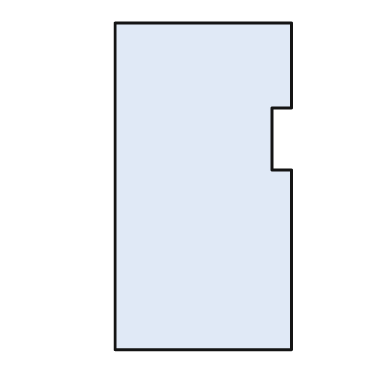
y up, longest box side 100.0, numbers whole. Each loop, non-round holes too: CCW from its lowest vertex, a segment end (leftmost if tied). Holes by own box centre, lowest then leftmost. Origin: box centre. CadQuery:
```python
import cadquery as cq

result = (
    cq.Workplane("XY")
    .moveTo(-27.0, -50.0)
    .lineTo(27.0, -50.0)
    .lineTo(27.0, 5.0)
    .lineTo(21.0, 5.0)
    .lineTo(21.0, 24.0)
    .lineTo(27.0, 24.0)
    .lineTo(27.0, 50.0)
    .lineTo(-27.0, 50.0)
    .close()
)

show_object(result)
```